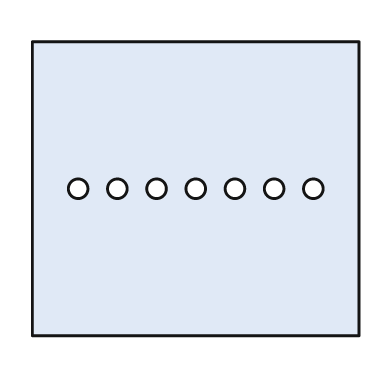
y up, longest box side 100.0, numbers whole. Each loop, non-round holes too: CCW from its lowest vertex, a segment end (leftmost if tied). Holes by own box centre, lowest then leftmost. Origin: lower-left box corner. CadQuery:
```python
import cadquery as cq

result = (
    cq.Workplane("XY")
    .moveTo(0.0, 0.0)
    .lineTo(100.0, 0.0)
    .lineTo(100.0, 90.0)
    .lineTo(0.0, 90.0)
    .close()
    .moveTo(14.0, 45.0)
    .circle(3.0)
    .moveTo(26.0, 45.0)
    .circle(3.0)
    .moveTo(38.0, 45.0)
    .circle(3.0)
    .moveTo(50.0, 45.0)
    .circle(3.0)
    .moveTo(62.0, 45.0)
    .circle(3.0)
    .moveTo(74.0, 45.0)
    .circle(3.0)
    .moveTo(86.0, 45.0)
    .circle(3.0)
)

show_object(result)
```